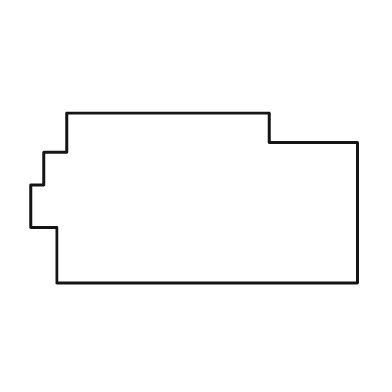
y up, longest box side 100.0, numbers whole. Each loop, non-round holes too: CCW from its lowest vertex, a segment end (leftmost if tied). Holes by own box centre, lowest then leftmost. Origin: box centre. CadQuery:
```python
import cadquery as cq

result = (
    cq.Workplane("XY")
    .moveTo(-42.0, -26.0)
    .lineTo(50.0, -26.0)
    .lineTo(50.0, 17.0)
    .lineTo(23.0, 17.0)
    .lineTo(23.0, 26.0)
    .lineTo(-39.0, 26.0)
    .lineTo(-39.0, 14.0)
    .lineTo(-46.0, 14.0)
    .lineTo(-46.0, 4.0)
    .lineTo(-50.0, 4.0)
    .lineTo(-50.0, -9.0)
    .lineTo(-42.0, -9.0)
    .close()
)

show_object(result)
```